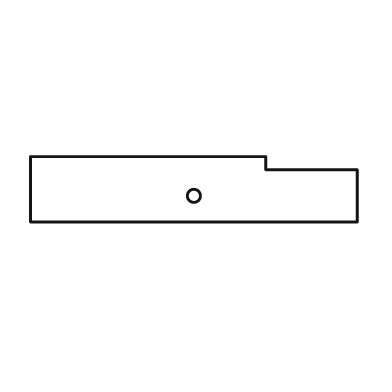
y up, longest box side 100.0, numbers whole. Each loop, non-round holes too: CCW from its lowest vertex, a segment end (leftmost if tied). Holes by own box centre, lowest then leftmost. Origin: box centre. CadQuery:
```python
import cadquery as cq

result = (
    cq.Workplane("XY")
    .moveTo(-50.0, -10.0)
    .lineTo(50.0, -10.0)
    .lineTo(50.0, 6.0)
    .lineTo(22.0, 6.0)
    .lineTo(22.0, 10.0)
    .lineTo(-50.0, 10.0)
    .close()
    .moveTo(0.0, -2.0)
    .circle(2.0)
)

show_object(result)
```